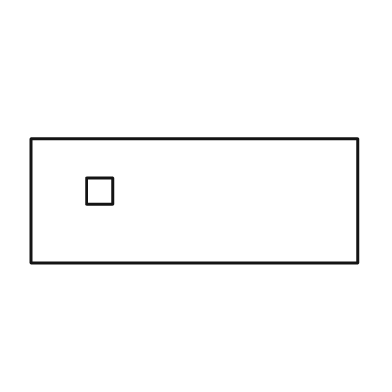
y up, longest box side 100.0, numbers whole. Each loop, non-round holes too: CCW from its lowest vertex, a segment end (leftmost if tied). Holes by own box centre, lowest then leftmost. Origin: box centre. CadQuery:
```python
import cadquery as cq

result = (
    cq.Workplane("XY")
    .moveTo(-50.0, -19.0)
    .lineTo(50.0, -19.0)
    .lineTo(50.0, 19.0)
    .lineTo(-50.0, 19.0)
    .close()
    .moveTo(-33.0, -1.0)
    .lineTo(-25.0, -1.0)
    .lineTo(-25.0, 7.0)
    .lineTo(-33.0, 7.0)
    .close()
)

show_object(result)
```